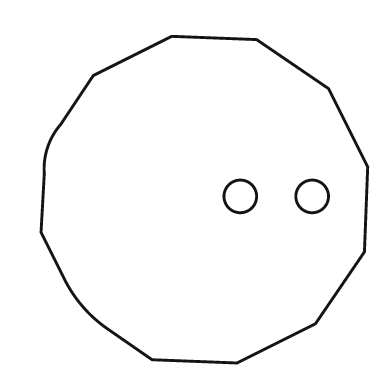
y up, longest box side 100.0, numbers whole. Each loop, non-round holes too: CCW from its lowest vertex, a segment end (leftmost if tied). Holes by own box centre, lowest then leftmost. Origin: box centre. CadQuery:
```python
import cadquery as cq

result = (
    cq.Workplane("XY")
    .moveTo(10.0, -50.0)
    .lineTo(34.0, -38.0)
    .lineTo(49.0, -16.0)
    .lineTo(50.0, 10.0)
    .lineTo(38.0, 34.0)
    .lineTo(16.0, 49.0)
    .lineTo(-10.0, 50.0)
    .lineTo(-34.0, 38.0)
    .lineTo(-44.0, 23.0)
    .threePointArc((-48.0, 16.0), (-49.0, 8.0))
    .lineTo(-50.0, -10.0)
    .lineTo(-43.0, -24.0)
    .threePointArc((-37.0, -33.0), (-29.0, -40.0))
    .lineTo(-16.0, -49.0)
    .close()
    .moveTo(11.0, 1.0)
    .circle(5.0)
    .moveTo(33.0, 1.0)
    .circle(5.0)
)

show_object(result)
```